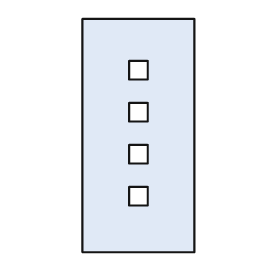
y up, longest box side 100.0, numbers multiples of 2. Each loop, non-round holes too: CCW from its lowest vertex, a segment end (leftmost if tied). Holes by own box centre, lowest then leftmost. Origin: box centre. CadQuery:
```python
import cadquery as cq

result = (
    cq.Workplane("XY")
    .moveTo(-24.0, -50.0)
    .lineTo(24.0, -50.0)
    .lineTo(24.0, 50.0)
    .lineTo(-24.0, 50.0)
    .close()
    .moveTo(-4.0, -30.0)
    .lineTo(4.0, -30.0)
    .lineTo(4.0, -22.0)
    .lineTo(-4.0, -22.0)
    .close()
    .moveTo(-4.0, -12.0)
    .lineTo(4.0, -12.0)
    .lineTo(4.0, -4.0)
    .lineTo(-4.0, -4.0)
    .close()
    .moveTo(-4.0, 6.0)
    .lineTo(4.0, 6.0)
    .lineTo(4.0, 14.0)
    .lineTo(-4.0, 14.0)
    .close()
    .moveTo(-4.0, 24.0)
    .lineTo(4.0, 24.0)
    .lineTo(4.0, 32.0)
    .lineTo(-4.0, 32.0)
    .close()
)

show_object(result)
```